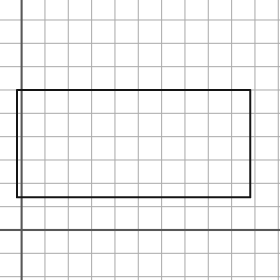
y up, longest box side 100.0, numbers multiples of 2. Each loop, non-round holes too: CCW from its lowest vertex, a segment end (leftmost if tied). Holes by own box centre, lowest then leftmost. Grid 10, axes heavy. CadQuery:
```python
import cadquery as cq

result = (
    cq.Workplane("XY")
    .moveTo(-2.0, 14.0)
    .lineTo(98.0, 14.0)
    .lineTo(98.0, 60.0)
    .lineTo(-2.0, 60.0)
    .close()
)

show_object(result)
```